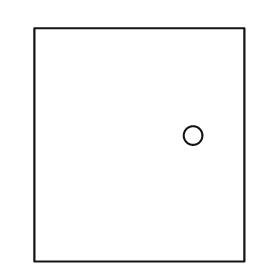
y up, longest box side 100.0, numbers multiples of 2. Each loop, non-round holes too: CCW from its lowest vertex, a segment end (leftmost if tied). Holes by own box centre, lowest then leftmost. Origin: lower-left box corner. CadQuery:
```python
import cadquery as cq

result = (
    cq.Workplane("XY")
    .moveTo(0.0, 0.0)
    .lineTo(90.0, 0.0)
    .lineTo(90.0, 100.0)
    .lineTo(0.0, 100.0)
    .close()
    .moveTo(68.0, 54.0)
    .circle(4.0)
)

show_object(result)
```